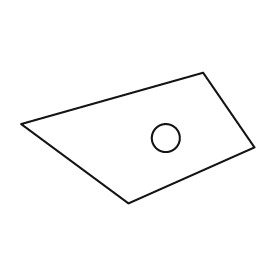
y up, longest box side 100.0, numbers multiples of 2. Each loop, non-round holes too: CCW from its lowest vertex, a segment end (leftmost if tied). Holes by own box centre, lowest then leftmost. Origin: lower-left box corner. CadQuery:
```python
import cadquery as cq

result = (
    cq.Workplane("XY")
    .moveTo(46.0, 0.0)
    .lineTo(100.0, 24.0)
    .lineTo(78.0, 56.0)
    .lineTo(0.0, 34.0)
    .close()
    .moveTo(62.0, 28.0)
    .circle(6.0)
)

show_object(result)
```